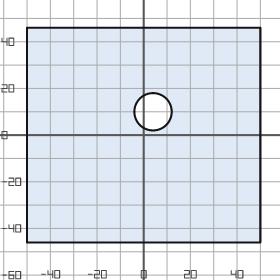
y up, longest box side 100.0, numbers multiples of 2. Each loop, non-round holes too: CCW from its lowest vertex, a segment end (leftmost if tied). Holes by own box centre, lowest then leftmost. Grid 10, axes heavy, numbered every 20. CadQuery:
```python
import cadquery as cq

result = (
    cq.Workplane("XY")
    .moveTo(-50.0, -46.0)
    .lineTo(50.0, -46.0)
    .lineTo(50.0, 46.0)
    .lineTo(-50.0, 46.0)
    .close()
    .moveTo(4.0, 10.0)
    .circle(8.0)
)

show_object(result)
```